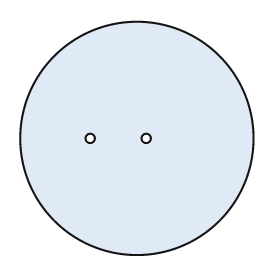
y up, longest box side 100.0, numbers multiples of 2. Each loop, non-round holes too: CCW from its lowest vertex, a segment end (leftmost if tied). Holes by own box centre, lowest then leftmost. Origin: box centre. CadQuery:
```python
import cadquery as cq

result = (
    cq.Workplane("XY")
    .moveTo(0.0, 0.0)
    .circle(50.0)
    .moveTo(-20.0, 0.0)
    .circle(2.0)
    .moveTo(4.0, 0.0)
    .circle(2.0)
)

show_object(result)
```